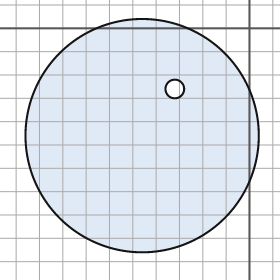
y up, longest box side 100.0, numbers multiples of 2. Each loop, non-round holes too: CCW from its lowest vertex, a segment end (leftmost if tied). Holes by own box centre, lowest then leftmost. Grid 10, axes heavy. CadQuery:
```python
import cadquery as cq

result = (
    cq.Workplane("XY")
    .moveTo(-46.0, -46.0)
    .circle(50.0)
    .moveTo(-32.0, -26.0)
    .circle(4.0)
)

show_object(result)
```